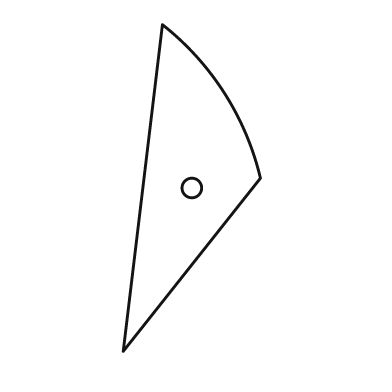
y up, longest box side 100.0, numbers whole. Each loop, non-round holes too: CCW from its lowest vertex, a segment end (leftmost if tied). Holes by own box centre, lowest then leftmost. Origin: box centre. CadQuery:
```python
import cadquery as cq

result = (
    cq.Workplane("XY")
    .moveTo(-21.0, -50.0)
    .lineTo(21.0, 3.0)
    .threePointArc((10.0, 29.0), (-9.0, 50.0))
    .close()
    .moveTo(0.0, 0.0)
    .circle(3.0)
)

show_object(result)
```